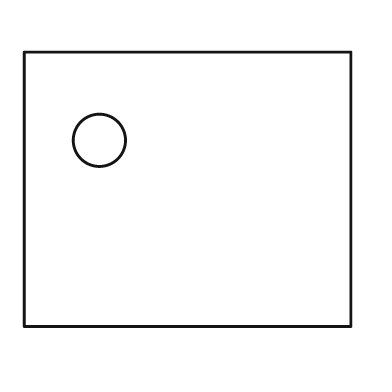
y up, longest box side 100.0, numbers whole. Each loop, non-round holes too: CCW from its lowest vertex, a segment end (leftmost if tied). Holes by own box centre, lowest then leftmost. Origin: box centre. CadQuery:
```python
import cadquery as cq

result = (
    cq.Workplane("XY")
    .moveTo(-50.0, -42.0)
    .lineTo(50.0, -42.0)
    .lineTo(50.0, 42.0)
    .lineTo(-50.0, 42.0)
    .close()
    .moveTo(-27.0, 15.0)
    .circle(8.0)
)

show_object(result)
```